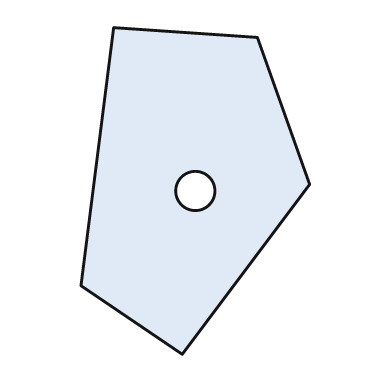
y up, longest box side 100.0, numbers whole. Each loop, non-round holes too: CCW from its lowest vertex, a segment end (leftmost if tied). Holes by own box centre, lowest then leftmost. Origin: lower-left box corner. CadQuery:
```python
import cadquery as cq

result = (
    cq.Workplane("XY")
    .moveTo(31.0, 0.0)
    .lineTo(70.0, 52.0)
    .lineTo(54.0, 97.0)
    .lineTo(10.0, 100.0)
    .lineTo(0.0, 21.0)
    .close()
    .moveTo(35.0, 50.0)
    .circle(6.0)
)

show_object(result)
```